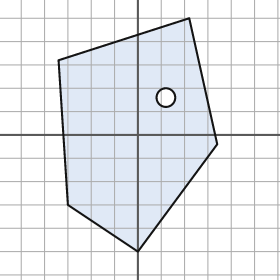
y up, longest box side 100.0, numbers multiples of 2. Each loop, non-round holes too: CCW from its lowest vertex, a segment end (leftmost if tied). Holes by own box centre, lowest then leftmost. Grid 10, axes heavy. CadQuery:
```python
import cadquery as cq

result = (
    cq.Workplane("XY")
    .moveTo(0.0, -50.0)
    .lineTo(34.0, -4.0)
    .lineTo(22.0, 50.0)
    .lineTo(-34.0, 32.0)
    .lineTo(-30.0, -30.0)
    .close()
    .moveTo(12.0, 16.0)
    .circle(4.0)
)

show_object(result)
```